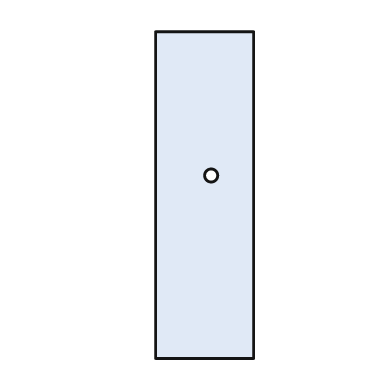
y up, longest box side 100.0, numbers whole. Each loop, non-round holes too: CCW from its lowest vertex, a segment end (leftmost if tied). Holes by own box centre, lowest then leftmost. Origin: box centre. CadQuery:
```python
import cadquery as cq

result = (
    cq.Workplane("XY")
    .moveTo(-15.0, -50.0)
    .lineTo(15.0, -50.0)
    .lineTo(15.0, 50.0)
    .lineTo(-15.0, 50.0)
    .close()
    .moveTo(2.0, 6.0)
    .circle(2.0)
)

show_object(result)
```